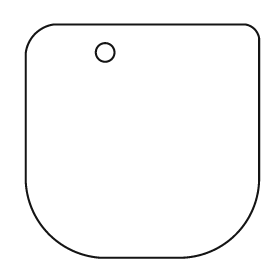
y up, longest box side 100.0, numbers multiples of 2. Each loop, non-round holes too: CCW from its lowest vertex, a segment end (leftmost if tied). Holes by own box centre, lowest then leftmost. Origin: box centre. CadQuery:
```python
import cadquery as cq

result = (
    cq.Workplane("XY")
    .moveTo(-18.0, -50.0)
    .lineTo(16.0, -50.0)
    .threePointArc((40.0, -40.0), (50.0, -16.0))
    .lineTo(50.0, 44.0)
    .threePointArc((48.0, 48.0), (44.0, 50.0))
    .lineTo(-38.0, 50.0)
    .threePointArc((-46.0, 46.0), (-50.0, 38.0))
    .lineTo(-50.0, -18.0)
    .threePointArc((-40.0, -40.0), (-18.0, -50.0))
    .close()
    .moveTo(-16.0, 38.0)
    .circle(4.0)
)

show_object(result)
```